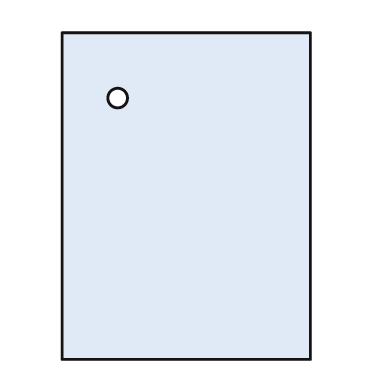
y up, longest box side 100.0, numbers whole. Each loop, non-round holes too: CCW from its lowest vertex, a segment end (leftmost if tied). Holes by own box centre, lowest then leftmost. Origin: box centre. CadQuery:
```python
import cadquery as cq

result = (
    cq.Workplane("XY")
    .moveTo(-38.0, -50.0)
    .lineTo(38.0, -50.0)
    .lineTo(38.0, 50.0)
    .lineTo(-38.0, 50.0)
    .close()
    .moveTo(-21.0, 30.0)
    .circle(3.0)
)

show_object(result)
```